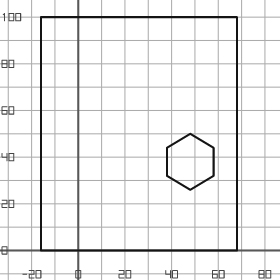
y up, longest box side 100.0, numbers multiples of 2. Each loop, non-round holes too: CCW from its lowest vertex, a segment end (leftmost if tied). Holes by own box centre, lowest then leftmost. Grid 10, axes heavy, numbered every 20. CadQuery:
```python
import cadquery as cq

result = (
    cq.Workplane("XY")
    .moveTo(-16.0, 0.0)
    .lineTo(68.0, 0.0)
    .lineTo(68.0, 100.0)
    .lineTo(-16.0, 100.0)
    .close()
    .moveTo(48.0, 26.0)
    .lineTo(58.0, 32.0)
    .lineTo(58.0, 44.0)
    .lineTo(48.0, 50.0)
    .lineTo(38.0, 44.0)
    .lineTo(38.0, 32.0)
    .close()
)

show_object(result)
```